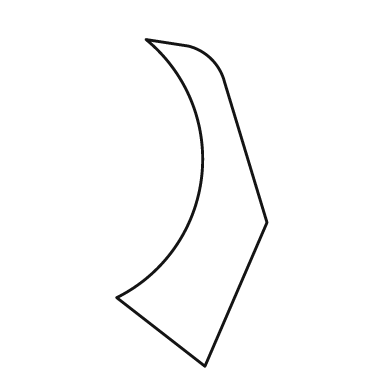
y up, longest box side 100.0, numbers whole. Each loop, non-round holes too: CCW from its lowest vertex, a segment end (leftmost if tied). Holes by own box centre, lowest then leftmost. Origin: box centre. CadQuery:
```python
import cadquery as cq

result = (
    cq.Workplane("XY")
    .moveTo(4.0, -50.0)
    .lineTo(23.0, -6.0)
    .lineTo(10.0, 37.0)
    .threePointArc((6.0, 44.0), (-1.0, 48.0))
    .lineTo(-14.0, 50.0)
    .threePointArc((3.0, 8.0), (-23.0, -29.0))
    .close()
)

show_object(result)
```